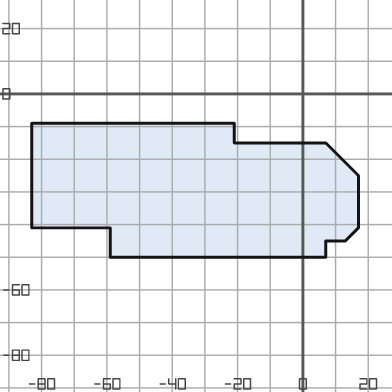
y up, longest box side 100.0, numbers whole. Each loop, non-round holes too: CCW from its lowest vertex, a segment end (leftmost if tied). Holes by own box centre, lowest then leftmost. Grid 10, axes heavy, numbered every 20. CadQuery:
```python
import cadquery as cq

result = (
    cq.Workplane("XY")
    .moveTo(-59.0, -50.0)
    .lineTo(7.0, -50.0)
    .lineTo(7.0, -45.0)
    .lineTo(13.0, -45.0)
    .lineTo(17.0, -41.0)
    .lineTo(17.0, -25.0)
    .lineTo(7.0, -15.0)
    .lineTo(-21.0, -15.0)
    .lineTo(-21.0, -9.0)
    .lineTo(-83.0, -9.0)
    .lineTo(-83.0, -41.0)
    .lineTo(-59.0, -41.0)
    .close()
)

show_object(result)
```